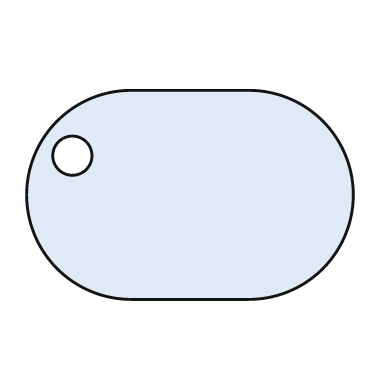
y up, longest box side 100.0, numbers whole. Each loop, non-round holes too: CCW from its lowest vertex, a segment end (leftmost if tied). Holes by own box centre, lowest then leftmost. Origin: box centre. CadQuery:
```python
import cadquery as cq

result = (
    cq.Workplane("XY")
    .moveTo(-18.0, -32.0)
    .lineTo(18.0, -32.0)
    .threePointArc((50.0, 0.0), (18.0, 32.0))
    .lineTo(-18.0, 32.0)
    .threePointArc((-50.0, 0.0), (-18.0, -32.0))
    .close()
    .moveTo(-36.0, 12.0)
    .circle(6.0)
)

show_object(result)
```